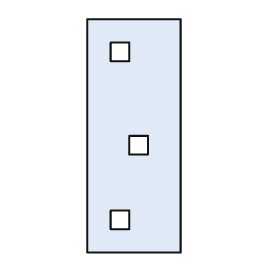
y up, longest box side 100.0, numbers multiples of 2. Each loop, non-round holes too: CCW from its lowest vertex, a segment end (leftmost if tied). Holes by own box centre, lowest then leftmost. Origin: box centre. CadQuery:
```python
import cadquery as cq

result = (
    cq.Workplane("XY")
    .moveTo(-20.0, -50.0)
    .lineTo(20.0, -50.0)
    .lineTo(20.0, 50.0)
    .lineTo(-20.0, 50.0)
    .close()
    .moveTo(-10.0, -40.0)
    .lineTo(-2.0, -40.0)
    .lineTo(-2.0, -32.0)
    .lineTo(-10.0, -32.0)
    .close()
    .moveTo(-2.0, -8.0)
    .lineTo(6.0, -8.0)
    .lineTo(6.0, 0.0)
    .lineTo(-2.0, 0.0)
    .close()
    .moveTo(-10.0, 32.0)
    .lineTo(-2.0, 32.0)
    .lineTo(-2.0, 40.0)
    .lineTo(-10.0, 40.0)
    .close()
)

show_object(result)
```